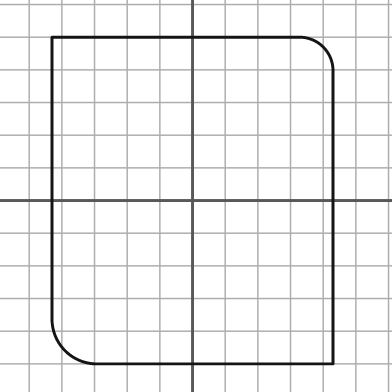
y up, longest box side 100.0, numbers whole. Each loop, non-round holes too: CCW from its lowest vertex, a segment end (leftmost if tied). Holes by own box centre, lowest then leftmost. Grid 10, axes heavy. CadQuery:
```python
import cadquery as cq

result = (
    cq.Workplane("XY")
    .moveTo(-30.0, -50.0)
    .lineTo(43.0, -50.0)
    .lineTo(43.0, 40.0)
    .threePointArc((40.0, 47.0), (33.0, 50.0))
    .lineTo(-43.0, 50.0)
    .lineTo(-43.0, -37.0)
    .threePointArc((-39.0, -46.0), (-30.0, -50.0))
    .close()
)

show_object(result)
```